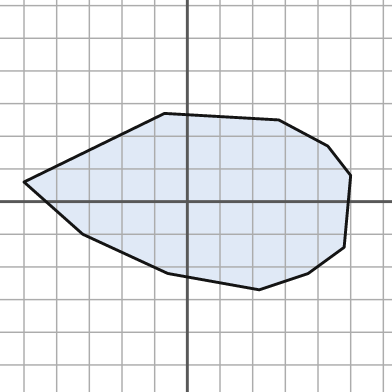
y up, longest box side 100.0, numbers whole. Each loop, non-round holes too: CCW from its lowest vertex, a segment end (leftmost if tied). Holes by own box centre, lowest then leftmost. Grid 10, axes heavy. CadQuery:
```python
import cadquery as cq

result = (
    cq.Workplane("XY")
    .moveTo(22.0, -27.0)
    .lineTo(37.0, -22.0)
    .lineTo(48.0, -14.0)
    .lineTo(50.0, 8.0)
    .lineTo(43.0, 17.0)
    .lineTo(28.0, 25.0)
    .lineTo(-7.0, 27.0)
    .lineTo(-50.0, 6.0)
    .lineTo(-32.0, -10.0)
    .lineTo(-6.0, -22.0)
    .close()
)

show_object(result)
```